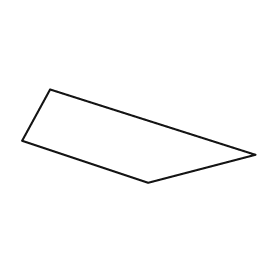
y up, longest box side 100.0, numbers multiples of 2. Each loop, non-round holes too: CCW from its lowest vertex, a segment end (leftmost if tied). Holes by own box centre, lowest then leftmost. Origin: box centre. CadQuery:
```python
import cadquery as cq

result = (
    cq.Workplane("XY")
    .moveTo(4.0, -20.0)
    .lineTo(50.0, -8.0)
    .lineTo(-38.0, 20.0)
    .lineTo(-50.0, -2.0)
    .close()
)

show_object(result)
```